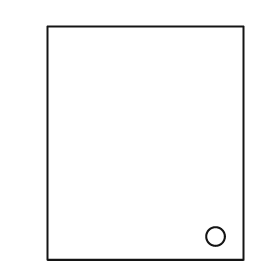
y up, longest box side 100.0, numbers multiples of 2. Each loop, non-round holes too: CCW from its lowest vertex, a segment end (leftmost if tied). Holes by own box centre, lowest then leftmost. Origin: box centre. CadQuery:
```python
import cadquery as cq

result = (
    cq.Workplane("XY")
    .moveTo(-42.0, -50.0)
    .lineTo(42.0, -50.0)
    .lineTo(42.0, 50.0)
    .lineTo(-42.0, 50.0)
    .close()
    .moveTo(30.0, -40.0)
    .circle(4.0)
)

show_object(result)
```